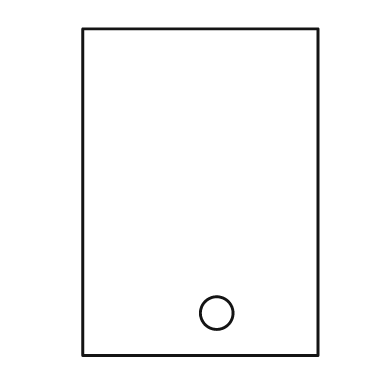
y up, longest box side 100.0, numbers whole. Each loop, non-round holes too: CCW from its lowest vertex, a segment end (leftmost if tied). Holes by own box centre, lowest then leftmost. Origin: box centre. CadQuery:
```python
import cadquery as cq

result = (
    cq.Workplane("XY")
    .moveTo(-36.0, -50.0)
    .lineTo(36.0, -50.0)
    .lineTo(36.0, 50.0)
    .lineTo(-36.0, 50.0)
    .close()
    .moveTo(5.0, -37.0)
    .circle(5.0)
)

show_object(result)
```